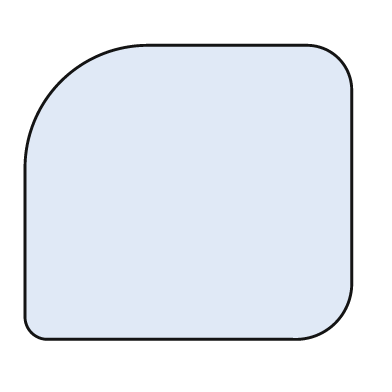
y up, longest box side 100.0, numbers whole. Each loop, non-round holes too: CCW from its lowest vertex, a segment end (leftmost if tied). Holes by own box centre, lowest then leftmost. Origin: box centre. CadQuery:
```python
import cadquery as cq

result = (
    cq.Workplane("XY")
    .moveTo(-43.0, -45.0)
    .lineTo(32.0, -45.0)
    .threePointArc((45.0, -40.0), (50.0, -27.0))
    .lineTo(50.0, 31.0)
    .threePointArc((46.0, 41.0), (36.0, 45.0))
    .lineTo(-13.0, 45.0)
    .threePointArc((-39.0, 34.0), (-50.0, 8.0))
    .lineTo(-50.0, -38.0)
    .threePointArc((-48.0, -43.0), (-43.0, -45.0))
    .close()
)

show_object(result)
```